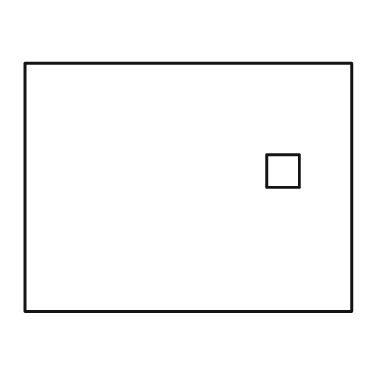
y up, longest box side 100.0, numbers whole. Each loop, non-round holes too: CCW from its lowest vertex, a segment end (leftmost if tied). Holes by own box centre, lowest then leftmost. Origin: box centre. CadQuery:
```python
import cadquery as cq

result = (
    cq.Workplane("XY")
    .moveTo(-50.0, -38.0)
    .lineTo(50.0, -38.0)
    .lineTo(50.0, 38.0)
    .lineTo(-50.0, 38.0)
    .close()
    .moveTo(24.0, 0.0)
    .lineTo(34.0, 0.0)
    .lineTo(34.0, 10.0)
    .lineTo(24.0, 10.0)
    .close()
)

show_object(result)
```